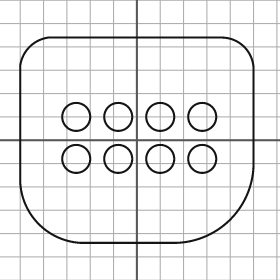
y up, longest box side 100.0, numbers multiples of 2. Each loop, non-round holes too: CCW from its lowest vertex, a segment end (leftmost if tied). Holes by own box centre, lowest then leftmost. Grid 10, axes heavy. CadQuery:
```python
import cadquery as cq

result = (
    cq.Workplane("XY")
    .moveTo(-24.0, -44.0)
    .lineTo(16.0, -44.0)
    .threePointArc((40.0, -34.0), (50.0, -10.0))
    .lineTo(50.0, 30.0)
    .threePointArc((46.0, 40.0), (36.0, 44.0))
    .lineTo(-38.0, 44.0)
    .threePointArc((-46.0, 40.0), (-50.0, 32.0))
    .lineTo(-50.0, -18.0)
    .threePointArc((-42.0, -36.0), (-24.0, -44.0))
    .close()
    .moveTo(-26.0, -8.0)
    .circle(6.0)
    .moveTo(-8.0, -8.0)
    .circle(6.0)
    .moveTo(10.0, -8.0)
    .circle(6.0)
    .moveTo(28.0, -8.0)
    .circle(6.0)
    .moveTo(-26.0, 10.0)
    .circle(6.0)
    .moveTo(-8.0, 10.0)
    .circle(6.0)
    .moveTo(10.0, 10.0)
    .circle(6.0)
    .moveTo(28.0, 10.0)
    .circle(6.0)
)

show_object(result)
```